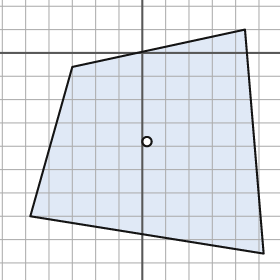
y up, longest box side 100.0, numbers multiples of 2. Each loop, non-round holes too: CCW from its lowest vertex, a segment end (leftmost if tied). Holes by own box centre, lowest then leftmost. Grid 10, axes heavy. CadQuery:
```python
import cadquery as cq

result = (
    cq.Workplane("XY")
    .moveTo(52.0, -86.0)
    .lineTo(44.0, 10.0)
    .lineTo(-30.0, -6.0)
    .lineTo(-48.0, -70.0)
    .close()
    .moveTo(2.0, -38.0)
    .circle(2.0)
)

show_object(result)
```